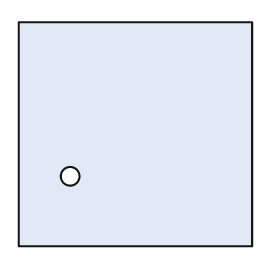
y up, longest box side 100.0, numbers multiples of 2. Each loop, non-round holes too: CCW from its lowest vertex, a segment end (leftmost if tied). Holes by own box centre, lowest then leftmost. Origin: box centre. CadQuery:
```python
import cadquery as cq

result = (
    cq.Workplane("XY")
    .moveTo(-50.0, -48.0)
    .lineTo(50.0, -48.0)
    .lineTo(50.0, 48.0)
    .lineTo(-50.0, 48.0)
    .close()
    .moveTo(-28.0, -18.0)
    .circle(4.0)
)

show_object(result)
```